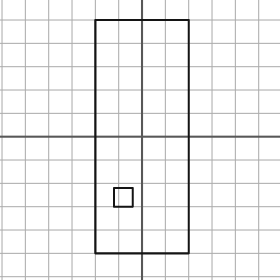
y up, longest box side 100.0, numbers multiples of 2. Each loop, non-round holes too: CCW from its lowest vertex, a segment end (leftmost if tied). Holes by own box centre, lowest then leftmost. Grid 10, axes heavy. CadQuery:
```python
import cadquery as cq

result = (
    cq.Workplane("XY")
    .moveTo(-20.0, -50.0)
    .lineTo(20.0, -50.0)
    .lineTo(20.0, 50.0)
    .lineTo(-20.0, 50.0)
    .close()
    .moveTo(-12.0, -30.0)
    .lineTo(-4.0, -30.0)
    .lineTo(-4.0, -22.0)
    .lineTo(-12.0, -22.0)
    .close()
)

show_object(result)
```